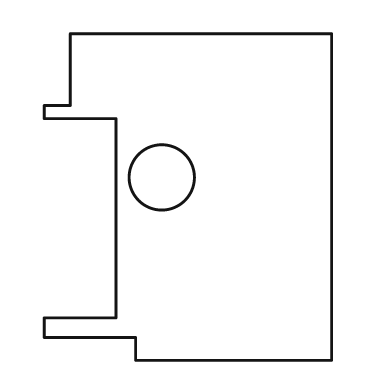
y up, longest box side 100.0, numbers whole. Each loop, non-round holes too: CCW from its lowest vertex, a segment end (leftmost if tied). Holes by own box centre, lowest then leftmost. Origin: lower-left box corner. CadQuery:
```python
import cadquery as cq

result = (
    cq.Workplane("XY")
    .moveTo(28.0, 0.0)
    .lineTo(88.0, 0.0)
    .lineTo(88.0, 100.0)
    .lineTo(8.0, 100.0)
    .lineTo(8.0, 78.0)
    .lineTo(0.0, 78.0)
    .lineTo(0.0, 74.0)
    .lineTo(22.0, 74.0)
    .lineTo(22.0, 13.0)
    .lineTo(0.0, 13.0)
    .lineTo(0.0, 7.0)
    .lineTo(28.0, 7.0)
    .close()
    .moveTo(36.0, 56.0)
    .circle(10.0)
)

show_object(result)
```